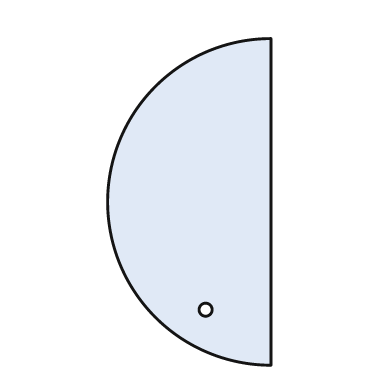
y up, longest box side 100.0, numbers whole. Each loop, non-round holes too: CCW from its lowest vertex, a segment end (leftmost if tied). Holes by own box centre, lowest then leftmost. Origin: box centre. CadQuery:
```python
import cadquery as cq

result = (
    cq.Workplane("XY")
    .moveTo(25.0, -50.0)
    .lineTo(25.0, 50.0)
    .threePointArc((-25.0, 0.0), (25.0, -50.0))
    .close()
    .moveTo(5.0, -33.0)
    .circle(2.0)
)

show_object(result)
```